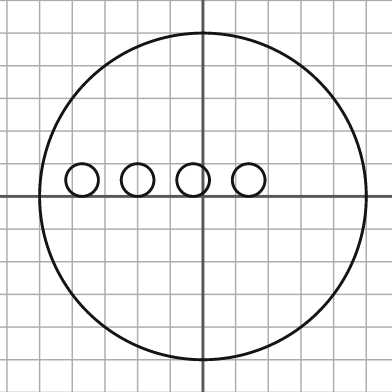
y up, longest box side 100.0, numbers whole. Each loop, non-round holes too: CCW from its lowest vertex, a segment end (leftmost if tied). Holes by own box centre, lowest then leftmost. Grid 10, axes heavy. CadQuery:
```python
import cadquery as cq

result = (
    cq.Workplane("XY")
    .moveTo(0.0, 0.0)
    .circle(50.0)
    .moveTo(-37.0, 5.0)
    .circle(5.0)
    .moveTo(-20.0, 5.0)
    .circle(5.0)
    .moveTo(-3.0, 5.0)
    .circle(5.0)
    .moveTo(14.0, 5.0)
    .circle(5.0)
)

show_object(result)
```